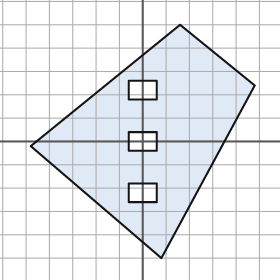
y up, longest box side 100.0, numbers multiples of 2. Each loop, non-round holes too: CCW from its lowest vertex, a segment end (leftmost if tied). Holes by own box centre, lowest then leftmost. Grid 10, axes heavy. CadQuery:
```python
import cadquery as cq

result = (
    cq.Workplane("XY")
    .moveTo(8.0, -50.0)
    .lineTo(48.0, 24.0)
    .lineTo(16.0, 50.0)
    .lineTo(-48.0, -2.0)
    .close()
    .moveTo(-6.0, -26.0)
    .lineTo(6.0, -26.0)
    .lineTo(6.0, -18.0)
    .lineTo(-6.0, -18.0)
    .close()
    .moveTo(-6.0, -4.0)
    .lineTo(6.0, -4.0)
    .lineTo(6.0, 4.0)
    .lineTo(-6.0, 4.0)
    .close()
    .moveTo(-6.0, 18.0)
    .lineTo(6.0, 18.0)
    .lineTo(6.0, 26.0)
    .lineTo(-6.0, 26.0)
    .close()
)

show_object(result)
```